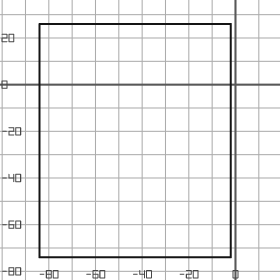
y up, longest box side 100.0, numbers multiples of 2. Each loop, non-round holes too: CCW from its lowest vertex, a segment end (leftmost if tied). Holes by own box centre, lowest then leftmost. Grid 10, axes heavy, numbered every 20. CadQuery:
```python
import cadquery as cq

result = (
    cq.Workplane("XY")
    .moveTo(-84.0, -74.0)
    .lineTo(-2.0, -74.0)
    .lineTo(-2.0, 26.0)
    .lineTo(-84.0, 26.0)
    .close()
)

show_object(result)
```